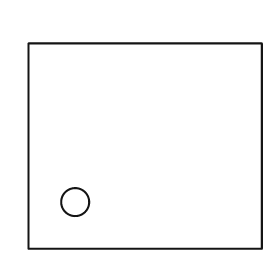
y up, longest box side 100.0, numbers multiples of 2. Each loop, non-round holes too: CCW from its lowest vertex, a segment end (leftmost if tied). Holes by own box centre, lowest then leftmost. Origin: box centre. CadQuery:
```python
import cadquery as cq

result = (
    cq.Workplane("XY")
    .moveTo(-50.0, -44.0)
    .lineTo(50.0, -44.0)
    .lineTo(50.0, 44.0)
    .lineTo(-50.0, 44.0)
    .close()
    .moveTo(-30.0, -24.0)
    .circle(6.0)
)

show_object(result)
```